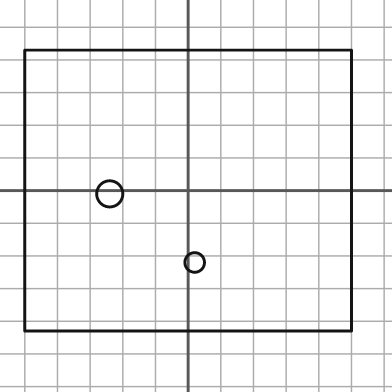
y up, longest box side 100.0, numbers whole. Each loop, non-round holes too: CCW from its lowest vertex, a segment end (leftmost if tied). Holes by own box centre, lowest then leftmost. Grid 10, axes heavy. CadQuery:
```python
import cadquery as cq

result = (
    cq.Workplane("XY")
    .moveTo(-50.0, -43.0)
    .lineTo(50.0, -43.0)
    .lineTo(50.0, 43.0)
    .lineTo(-50.0, 43.0)
    .close()
    .moveTo(2.0, -22.0)
    .circle(3.0)
    .moveTo(-24.0, -1.0)
    .circle(4.0)
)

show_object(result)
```